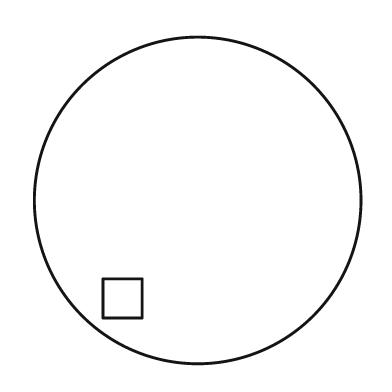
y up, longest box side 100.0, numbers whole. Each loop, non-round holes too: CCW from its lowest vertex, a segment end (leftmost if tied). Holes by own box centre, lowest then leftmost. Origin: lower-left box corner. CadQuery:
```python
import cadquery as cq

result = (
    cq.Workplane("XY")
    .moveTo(50.0, 50.0)
    .circle(50.0)
    .moveTo(21.0, 14.0)
    .lineTo(33.0, 14.0)
    .lineTo(33.0, 26.0)
    .lineTo(21.0, 26.0)
    .close()
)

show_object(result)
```